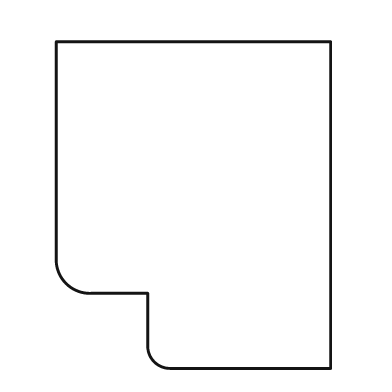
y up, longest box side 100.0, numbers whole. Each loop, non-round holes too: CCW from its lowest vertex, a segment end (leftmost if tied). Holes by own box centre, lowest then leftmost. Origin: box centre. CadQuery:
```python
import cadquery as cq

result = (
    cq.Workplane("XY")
    .moveTo(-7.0, -50.0)
    .lineTo(42.0, -50.0)
    .lineTo(42.0, 50.0)
    .lineTo(-42.0, 50.0)
    .lineTo(-42.0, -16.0)
    .threePointArc((-39.0, -24.0), (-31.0, -27.0))
    .lineTo(-14.0, -27.0)
    .lineTo(-14.0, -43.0)
    .threePointArc((-12.0, -48.0), (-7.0, -50.0))
    .close()
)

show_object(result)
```